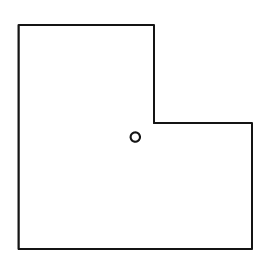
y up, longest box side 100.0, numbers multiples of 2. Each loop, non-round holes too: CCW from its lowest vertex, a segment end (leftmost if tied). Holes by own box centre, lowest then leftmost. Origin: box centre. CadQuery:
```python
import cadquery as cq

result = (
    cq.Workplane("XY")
    .moveTo(-50.0, -48.0)
    .lineTo(50.0, -48.0)
    .lineTo(50.0, 6.0)
    .lineTo(8.0, 6.0)
    .lineTo(8.0, 48.0)
    .lineTo(-50.0, 48.0)
    .close()
    .moveTo(0.0, 0.0)
    .circle(2.0)
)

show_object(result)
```